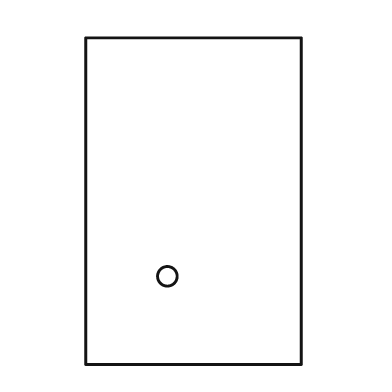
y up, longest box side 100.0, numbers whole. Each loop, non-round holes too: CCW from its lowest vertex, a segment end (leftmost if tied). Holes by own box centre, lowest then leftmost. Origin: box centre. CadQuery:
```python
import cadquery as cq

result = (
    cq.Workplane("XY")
    .moveTo(-33.0, -50.0)
    .lineTo(33.0, -50.0)
    .lineTo(33.0, 50.0)
    .lineTo(-33.0, 50.0)
    .close()
    .moveTo(-8.0, -23.0)
    .circle(3.0)
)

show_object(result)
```